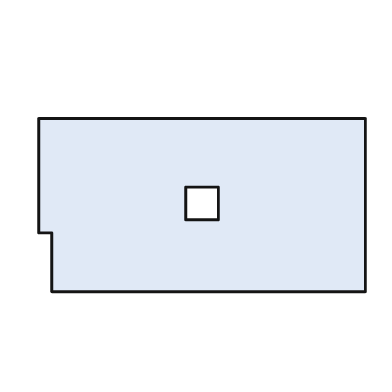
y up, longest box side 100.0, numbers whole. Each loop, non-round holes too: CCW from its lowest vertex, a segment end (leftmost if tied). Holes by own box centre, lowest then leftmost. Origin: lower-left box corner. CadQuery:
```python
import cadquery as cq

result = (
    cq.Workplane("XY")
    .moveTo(4.0, 0.0)
    .lineTo(100.0, 0.0)
    .lineTo(100.0, 53.0)
    .lineTo(0.0, 53.0)
    .lineTo(0.0, 18.0)
    .lineTo(4.0, 18.0)
    .close()
    .moveTo(45.0, 22.0)
    .lineTo(55.0, 22.0)
    .lineTo(55.0, 32.0)
    .lineTo(45.0, 32.0)
    .close()
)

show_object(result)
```